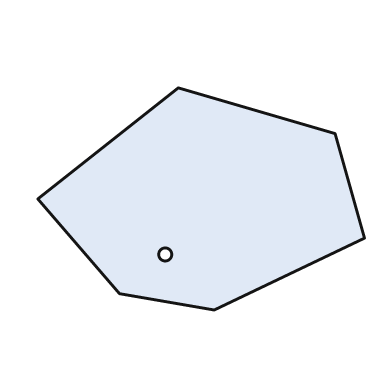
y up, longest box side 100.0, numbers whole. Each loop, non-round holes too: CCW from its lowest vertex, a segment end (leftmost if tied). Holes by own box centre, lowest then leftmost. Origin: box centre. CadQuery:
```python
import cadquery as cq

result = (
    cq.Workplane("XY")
    .moveTo(4.0, -34.0)
    .lineTo(50.0, -12.0)
    .lineTo(41.0, 20.0)
    .lineTo(-7.0, 34.0)
    .lineTo(-50.0, 0.0)
    .lineTo(-25.0, -29.0)
    .close()
    .moveTo(-11.0, -17.0)
    .circle(2.0)
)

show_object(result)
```